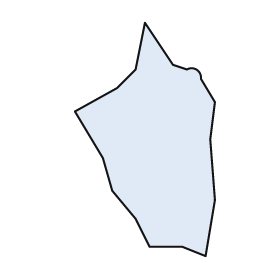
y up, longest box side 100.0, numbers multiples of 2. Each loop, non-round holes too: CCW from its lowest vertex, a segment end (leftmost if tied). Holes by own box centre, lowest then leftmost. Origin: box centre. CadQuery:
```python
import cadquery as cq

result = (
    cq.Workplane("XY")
    .moveTo(26.0, -50.0)
    .lineTo(30.0, -26.0)
    .lineTo(28.0, 0.0)
    .lineTo(30.0, 16.0)
    .lineTo(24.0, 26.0)
    .threePointArc((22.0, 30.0), (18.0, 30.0))
    .lineTo(12.0, 32.0)
    .lineTo(0.0, 50.0)
    .lineTo(-4.0, 30.0)
    .lineTo(-12.0, 22.0)
    .lineTo(-30.0, 12.0)
    .lineTo(-18.0, -8.0)
    .lineTo(-14.0, -22.0)
    .lineTo(-4.0, -34.0)
    .lineTo(2.0, -46.0)
    .lineTo(16.0, -46.0)
    .close()
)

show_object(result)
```